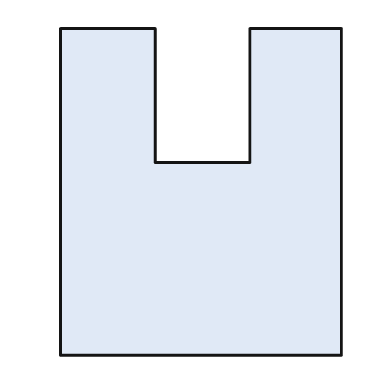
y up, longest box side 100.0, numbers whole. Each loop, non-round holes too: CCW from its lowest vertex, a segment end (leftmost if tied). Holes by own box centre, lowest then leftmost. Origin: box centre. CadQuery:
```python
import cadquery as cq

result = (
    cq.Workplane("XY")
    .moveTo(-43.0, -50.0)
    .lineTo(43.0, -50.0)
    .lineTo(43.0, 50.0)
    .lineTo(15.0, 50.0)
    .lineTo(15.0, 9.0)
    .lineTo(-14.0, 9.0)
    .lineTo(-14.0, 50.0)
    .lineTo(-43.0, 50.0)
    .close()
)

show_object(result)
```